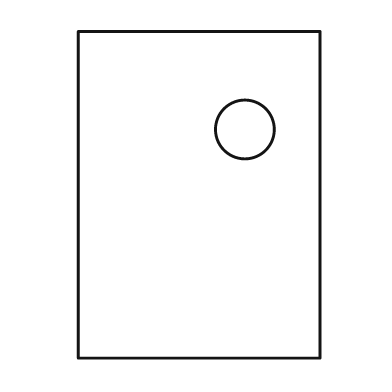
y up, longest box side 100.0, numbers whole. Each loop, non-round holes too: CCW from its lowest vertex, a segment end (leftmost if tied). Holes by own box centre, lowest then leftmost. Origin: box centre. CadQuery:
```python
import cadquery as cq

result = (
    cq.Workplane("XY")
    .moveTo(-37.0, -50.0)
    .lineTo(37.0, -50.0)
    .lineTo(37.0, 50.0)
    .lineTo(-37.0, 50.0)
    .close()
    .moveTo(14.0, 20.0)
    .circle(9.0)
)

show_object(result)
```